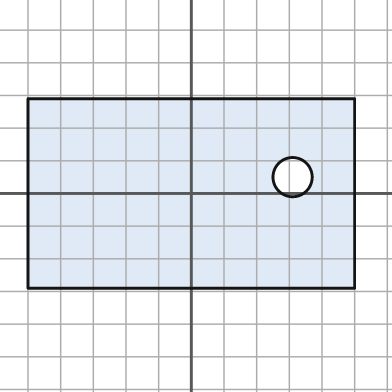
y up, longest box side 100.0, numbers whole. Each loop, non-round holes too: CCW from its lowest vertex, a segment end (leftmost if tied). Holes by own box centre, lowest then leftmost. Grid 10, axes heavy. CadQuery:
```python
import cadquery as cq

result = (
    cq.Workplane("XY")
    .moveTo(-50.0, -29.0)
    .lineTo(50.0, -29.0)
    .lineTo(50.0, 29.0)
    .lineTo(-50.0, 29.0)
    .close()
    .moveTo(31.0, 5.0)
    .circle(6.0)
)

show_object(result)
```